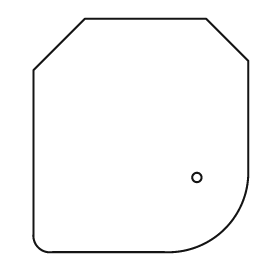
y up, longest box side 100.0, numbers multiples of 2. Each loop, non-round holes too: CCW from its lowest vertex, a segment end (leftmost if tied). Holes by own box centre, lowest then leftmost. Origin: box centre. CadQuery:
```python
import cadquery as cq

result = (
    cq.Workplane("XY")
    .moveTo(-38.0, -50.0)
    .lineTo(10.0, -50.0)
    .threePointArc((36.0, -40.0), (46.0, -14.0))
    .lineTo(46.0, 32.0)
    .lineTo(28.0, 50.0)
    .lineTo(-24.0, 50.0)
    .lineTo(-46.0, 28.0)
    .lineTo(-46.0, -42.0)
    .threePointArc((-44.0, -48.0), (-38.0, -50.0))
    .close()
    .moveTo(24.0, -18.0)
    .circle(2.0)
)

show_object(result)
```